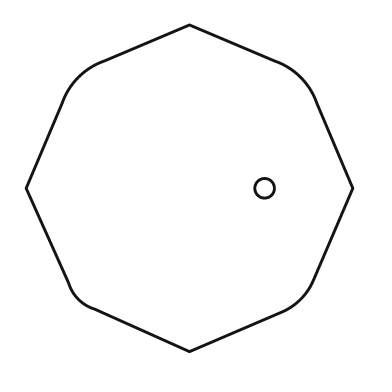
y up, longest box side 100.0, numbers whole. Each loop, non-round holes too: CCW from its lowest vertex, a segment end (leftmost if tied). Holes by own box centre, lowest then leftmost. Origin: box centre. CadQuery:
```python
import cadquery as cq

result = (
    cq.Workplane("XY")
    .moveTo(0.0, -50.0)
    .lineTo(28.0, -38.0)
    .threePointArc((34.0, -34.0), (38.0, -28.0))
    .lineTo(50.0, 0.0)
    .lineTo(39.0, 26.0)
    .threePointArc((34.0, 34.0), (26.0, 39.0))
    .lineTo(0.0, 50.0)
    .lineTo(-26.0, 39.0)
    .threePointArc((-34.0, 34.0), (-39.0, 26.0))
    .lineTo(-50.0, 0.0)
    .lineTo(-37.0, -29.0)
    .threePointArc((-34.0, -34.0), (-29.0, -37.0))
    .close()
    .moveTo(23.0, 0.0)
    .circle(3.0)
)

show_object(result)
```